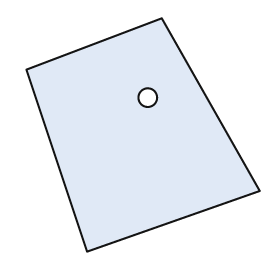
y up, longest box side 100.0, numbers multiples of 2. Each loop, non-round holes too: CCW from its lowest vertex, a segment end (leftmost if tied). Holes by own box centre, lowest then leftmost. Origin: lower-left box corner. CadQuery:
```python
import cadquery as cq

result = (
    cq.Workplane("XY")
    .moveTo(26.0, 0.0)
    .lineTo(100.0, 26.0)
    .lineTo(58.0, 100.0)
    .lineTo(0.0, 78.0)
    .close()
    .moveTo(52.0, 66.0)
    .circle(4.0)
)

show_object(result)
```